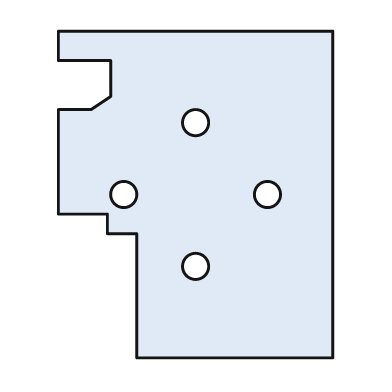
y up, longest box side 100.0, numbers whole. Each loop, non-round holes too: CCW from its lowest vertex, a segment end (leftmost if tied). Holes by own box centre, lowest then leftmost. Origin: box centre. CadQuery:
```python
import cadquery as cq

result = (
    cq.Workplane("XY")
    .moveTo(-18.0, -50.0)
    .lineTo(42.0, -50.0)
    .lineTo(42.0, 50.0)
    .lineTo(-42.0, 50.0)
    .lineTo(-42.0, 41.0)
    .lineTo(-26.0, 41.0)
    .lineTo(-26.0, 30.0)
    .lineTo(-32.0, 26.0)
    .lineTo(-42.0, 26.0)
    .lineTo(-42.0, -6.0)
    .lineTo(-27.0, -6.0)
    .lineTo(-27.0, -12.0)
    .lineTo(-18.0, -12.0)
    .close()
    .moveTo(0.0, -22.0)
    .circle(4.0)
    .moveTo(-22.0, 0.0)
    .circle(4.0)
    .moveTo(22.0, 0.0)
    .circle(4.0)
    .moveTo(0.0, 22.0)
    .circle(4.0)
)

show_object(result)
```